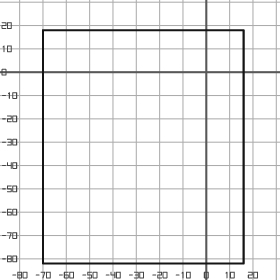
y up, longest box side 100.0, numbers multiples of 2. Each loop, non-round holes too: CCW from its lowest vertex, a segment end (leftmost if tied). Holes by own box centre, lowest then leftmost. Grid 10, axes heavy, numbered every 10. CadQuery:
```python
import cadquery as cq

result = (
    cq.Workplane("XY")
    .moveTo(-70.0, -82.0)
    .lineTo(16.0, -82.0)
    .lineTo(16.0, 18.0)
    .lineTo(-70.0, 18.0)
    .close()
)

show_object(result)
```